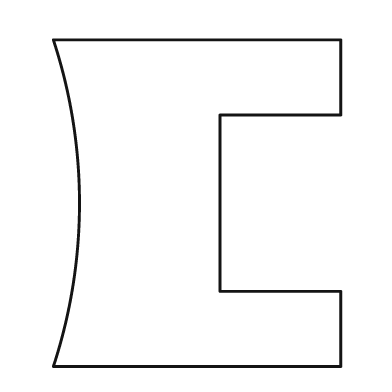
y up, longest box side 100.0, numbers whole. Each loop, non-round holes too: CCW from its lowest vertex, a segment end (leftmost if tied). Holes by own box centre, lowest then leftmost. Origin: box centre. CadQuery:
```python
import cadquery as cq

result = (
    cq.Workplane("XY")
    .moveTo(-44.0, -50.0)
    .lineTo(44.0, -50.0)
    .lineTo(44.0, -27.0)
    .lineTo(7.0, -27.0)
    .lineTo(7.0, 27.0)
    .lineTo(44.0, 27.0)
    .lineTo(44.0, 50.0)
    .lineTo(-44.0, 50.0)
    .threePointArc((-36.0, 0.0), (-44.0, -50.0))
    .close()
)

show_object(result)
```